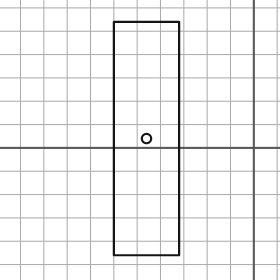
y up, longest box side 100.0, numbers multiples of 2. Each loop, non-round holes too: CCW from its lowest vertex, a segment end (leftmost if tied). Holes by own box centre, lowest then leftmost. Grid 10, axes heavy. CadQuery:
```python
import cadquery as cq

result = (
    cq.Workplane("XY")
    .moveTo(-60.0, -46.0)
    .lineTo(-32.0, -46.0)
    .lineTo(-32.0, 54.0)
    .lineTo(-60.0, 54.0)
    .close()
    .moveTo(-46.0, 4.0)
    .circle(2.0)
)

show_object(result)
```